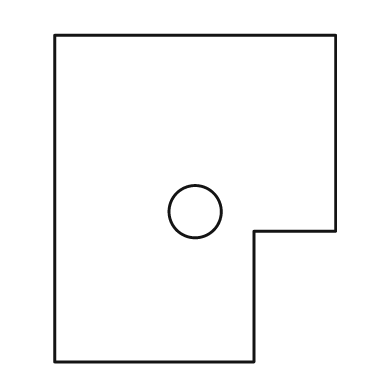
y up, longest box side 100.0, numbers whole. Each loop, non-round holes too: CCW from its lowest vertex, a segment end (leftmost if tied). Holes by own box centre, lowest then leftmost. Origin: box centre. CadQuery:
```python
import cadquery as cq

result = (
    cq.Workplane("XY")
    .moveTo(-43.0, -50.0)
    .lineTo(18.0, -50.0)
    .lineTo(18.0, -10.0)
    .lineTo(43.0, -10.0)
    .lineTo(43.0, 50.0)
    .lineTo(-43.0, 50.0)
    .close()
    .moveTo(0.0, -4.0)
    .circle(8.0)
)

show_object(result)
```